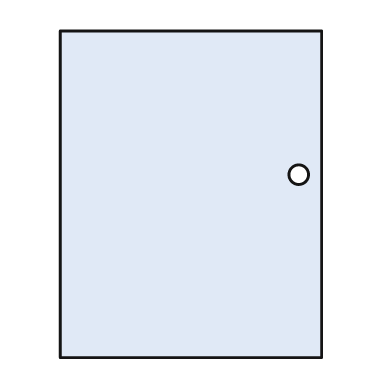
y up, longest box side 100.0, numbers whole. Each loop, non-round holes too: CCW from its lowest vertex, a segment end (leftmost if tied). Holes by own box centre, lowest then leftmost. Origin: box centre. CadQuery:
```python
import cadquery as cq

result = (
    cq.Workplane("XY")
    .moveTo(-40.0, -50.0)
    .lineTo(40.0, -50.0)
    .lineTo(40.0, 50.0)
    .lineTo(-40.0, 50.0)
    .close()
    .moveTo(33.0, 6.0)
    .circle(3.0)
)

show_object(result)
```